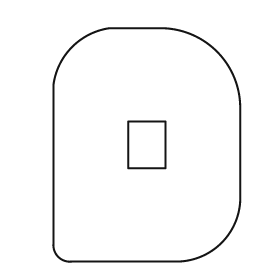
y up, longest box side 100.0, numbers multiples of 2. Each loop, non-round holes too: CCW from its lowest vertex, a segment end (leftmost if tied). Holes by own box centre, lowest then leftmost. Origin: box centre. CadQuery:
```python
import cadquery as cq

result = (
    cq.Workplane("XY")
    .moveTo(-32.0, -50.0)
    .lineTo(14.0, -50.0)
    .threePointArc((32.0, -42.0), (40.0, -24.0))
    .lineTo(40.0, 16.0)
    .threePointArc((30.0, 40.0), (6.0, 50.0))
    .lineTo(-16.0, 50.0)
    .threePointArc((-32.0, 42.0), (-40.0, 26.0))
    .lineTo(-40.0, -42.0)
    .threePointArc((-38.0, -48.0), (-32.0, -50.0))
    .close()
    .moveTo(-8.0, -10.0)
    .lineTo(8.0, -10.0)
    .lineTo(8.0, 10.0)
    .lineTo(-8.0, 10.0)
    .close()
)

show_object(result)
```